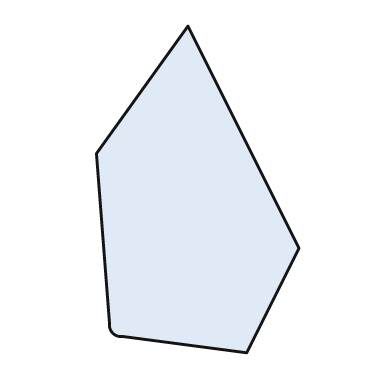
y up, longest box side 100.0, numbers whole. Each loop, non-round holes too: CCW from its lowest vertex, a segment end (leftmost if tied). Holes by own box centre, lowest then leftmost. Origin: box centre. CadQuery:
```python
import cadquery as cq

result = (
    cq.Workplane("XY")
    .moveTo(15.0, -50.0)
    .lineTo(31.0, -18.0)
    .lineTo(-3.0, 50.0)
    .lineTo(-31.0, 11.0)
    .lineTo(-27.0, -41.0)
    .threePointArc((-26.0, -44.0), (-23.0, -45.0))
    .close()
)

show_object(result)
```